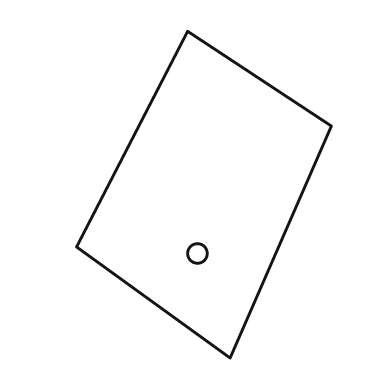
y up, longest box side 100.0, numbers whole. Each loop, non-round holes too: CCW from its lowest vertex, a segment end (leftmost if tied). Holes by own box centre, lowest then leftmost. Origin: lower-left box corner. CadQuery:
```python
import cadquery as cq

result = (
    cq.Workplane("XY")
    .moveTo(47.0, 0.0)
    .lineTo(78.0, 71.0)
    .lineTo(34.0, 100.0)
    .lineTo(0.0, 34.0)
    .close()
    .moveTo(37.0, 32.0)
    .circle(3.0)
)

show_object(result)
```